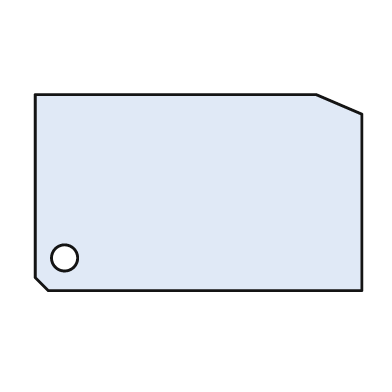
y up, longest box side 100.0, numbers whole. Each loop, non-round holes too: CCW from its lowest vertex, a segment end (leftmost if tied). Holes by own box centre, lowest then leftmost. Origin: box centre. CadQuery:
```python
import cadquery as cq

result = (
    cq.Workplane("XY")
    .moveTo(-46.0, -30.0)
    .lineTo(50.0, -30.0)
    .lineTo(50.0, 24.0)
    .lineTo(36.0, 30.0)
    .lineTo(-50.0, 30.0)
    .lineTo(-50.0, -26.0)
    .close()
    .moveTo(-41.0, -20.0)
    .circle(4.0)
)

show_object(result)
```